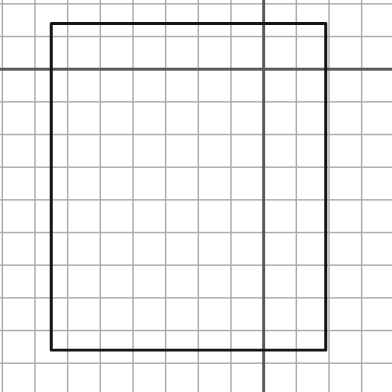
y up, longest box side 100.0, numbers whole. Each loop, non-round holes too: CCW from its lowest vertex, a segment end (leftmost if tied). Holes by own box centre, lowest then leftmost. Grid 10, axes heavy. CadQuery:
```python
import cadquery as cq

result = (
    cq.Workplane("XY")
    .moveTo(-65.0, -86.0)
    .lineTo(19.0, -86.0)
    .lineTo(19.0, 14.0)
    .lineTo(-65.0, 14.0)
    .close()
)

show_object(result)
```